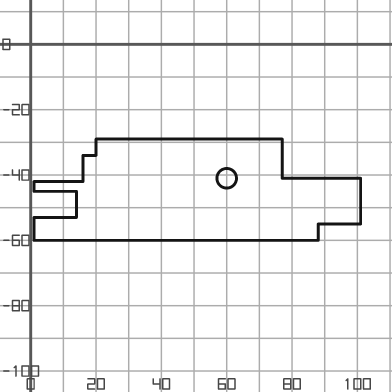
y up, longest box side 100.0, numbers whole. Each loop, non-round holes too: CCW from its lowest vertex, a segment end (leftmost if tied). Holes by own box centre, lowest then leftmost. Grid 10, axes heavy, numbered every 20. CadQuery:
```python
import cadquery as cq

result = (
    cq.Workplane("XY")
    .moveTo(1.0, -60.0)
    .lineTo(88.0, -60.0)
    .lineTo(88.0, -55.0)
    .lineTo(101.0, -55.0)
    .lineTo(101.0, -41.0)
    .lineTo(77.0, -41.0)
    .lineTo(77.0, -29.0)
    .lineTo(20.0, -29.0)
    .lineTo(20.0, -34.0)
    .lineTo(16.0, -34.0)
    .lineTo(16.0, -42.0)
    .lineTo(1.0, -42.0)
    .lineTo(1.0, -45.0)
    .lineTo(14.0, -45.0)
    .lineTo(14.0, -53.0)
    .lineTo(1.0, -53.0)
    .close()
    .moveTo(60.0, -41.0)
    .circle(3.0)
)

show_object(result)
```